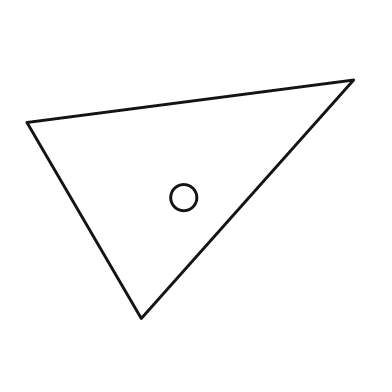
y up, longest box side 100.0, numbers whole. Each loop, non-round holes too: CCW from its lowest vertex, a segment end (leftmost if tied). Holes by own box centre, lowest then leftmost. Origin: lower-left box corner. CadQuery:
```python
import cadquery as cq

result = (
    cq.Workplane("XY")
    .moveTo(35.0, 0.0)
    .lineTo(100.0, 73.0)
    .lineTo(0.0, 60.0)
    .close()
    .moveTo(48.0, 37.0)
    .circle(4.0)
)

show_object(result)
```